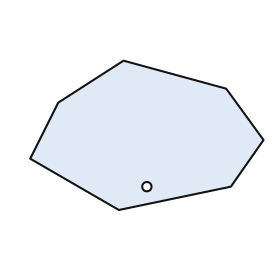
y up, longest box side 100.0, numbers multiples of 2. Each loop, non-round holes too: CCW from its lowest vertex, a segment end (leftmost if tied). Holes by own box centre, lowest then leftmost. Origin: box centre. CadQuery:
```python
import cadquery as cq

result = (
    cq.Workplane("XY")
    .moveTo(-12.0, -32.0)
    .lineTo(36.0, -22.0)
    .lineTo(50.0, -2.0)
    .lineTo(34.0, 20.0)
    .lineTo(-10.0, 32.0)
    .lineTo(-38.0, 14.0)
    .lineTo(-50.0, -10.0)
    .close()
    .moveTo(0.0, -22.0)
    .circle(2.0)
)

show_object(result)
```